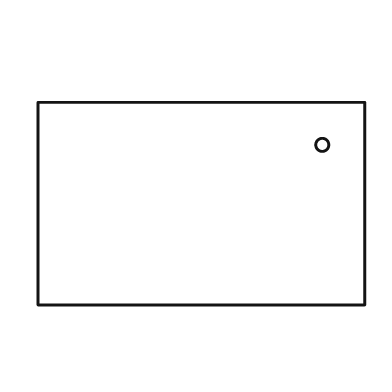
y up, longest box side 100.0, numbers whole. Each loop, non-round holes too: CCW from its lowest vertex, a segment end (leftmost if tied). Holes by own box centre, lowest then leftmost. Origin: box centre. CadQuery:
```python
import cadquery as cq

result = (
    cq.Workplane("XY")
    .moveTo(-50.0, -31.0)
    .lineTo(50.0, -31.0)
    .lineTo(50.0, 31.0)
    .lineTo(-50.0, 31.0)
    .close()
    .moveTo(37.0, 18.0)
    .circle(2.0)
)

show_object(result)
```